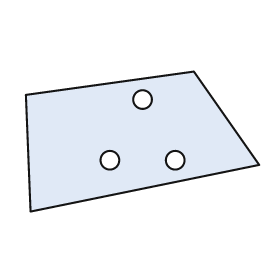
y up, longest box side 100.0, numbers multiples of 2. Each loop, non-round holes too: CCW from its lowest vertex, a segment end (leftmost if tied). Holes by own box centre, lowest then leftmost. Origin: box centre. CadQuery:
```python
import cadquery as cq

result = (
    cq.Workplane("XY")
    .moveTo(-48.0, -30.0)
    .lineTo(50.0, -10.0)
    .lineTo(22.0, 30.0)
    .lineTo(-50.0, 20.0)
    .close()
    .moveTo(-14.0, -8.0)
    .circle(4.0)
    .moveTo(14.0, -8.0)
    .circle(4.0)
    .moveTo(0.0, 18.0)
    .circle(4.0)
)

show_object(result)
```